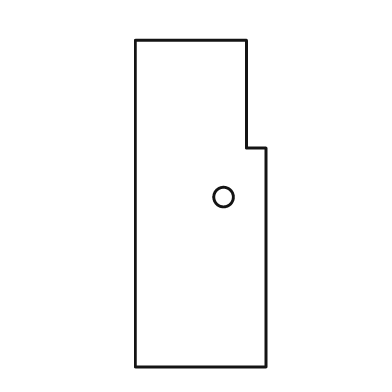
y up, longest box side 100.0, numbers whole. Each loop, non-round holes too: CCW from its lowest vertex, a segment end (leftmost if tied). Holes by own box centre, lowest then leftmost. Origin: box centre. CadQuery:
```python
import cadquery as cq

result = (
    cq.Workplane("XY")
    .moveTo(-20.0, -50.0)
    .lineTo(20.0, -50.0)
    .lineTo(20.0, 17.0)
    .lineTo(14.0, 17.0)
    .lineTo(14.0, 50.0)
    .lineTo(-20.0, 50.0)
    .close()
    .moveTo(7.0, 2.0)
    .circle(3.0)
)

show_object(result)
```